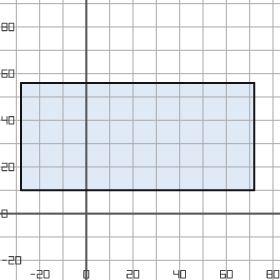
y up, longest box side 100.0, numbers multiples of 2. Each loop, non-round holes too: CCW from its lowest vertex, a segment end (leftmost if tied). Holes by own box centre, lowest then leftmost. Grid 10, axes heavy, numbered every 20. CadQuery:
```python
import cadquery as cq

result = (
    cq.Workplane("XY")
    .moveTo(-28.0, 10.0)
    .lineTo(72.0, 10.0)
    .lineTo(72.0, 56.0)
    .lineTo(-28.0, 56.0)
    .close()
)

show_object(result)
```